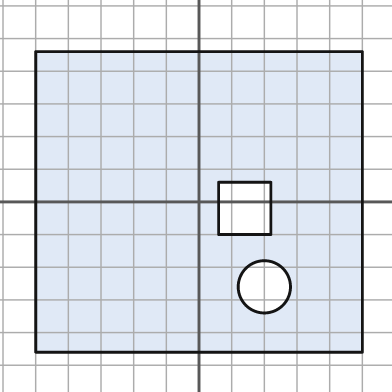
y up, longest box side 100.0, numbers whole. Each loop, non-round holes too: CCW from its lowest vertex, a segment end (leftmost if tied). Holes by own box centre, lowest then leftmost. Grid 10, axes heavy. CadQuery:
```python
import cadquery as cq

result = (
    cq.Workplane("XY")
    .moveTo(-50.0, -46.0)
    .lineTo(50.0, -46.0)
    .lineTo(50.0, 46.0)
    .lineTo(-50.0, 46.0)
    .close()
    .moveTo(20.0, -26.0)
    .circle(8.0)
    .moveTo(6.0, -10.0)
    .lineTo(22.0, -10.0)
    .lineTo(22.0, 6.0)
    .lineTo(6.0, 6.0)
    .close()
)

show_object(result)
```